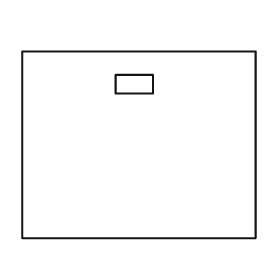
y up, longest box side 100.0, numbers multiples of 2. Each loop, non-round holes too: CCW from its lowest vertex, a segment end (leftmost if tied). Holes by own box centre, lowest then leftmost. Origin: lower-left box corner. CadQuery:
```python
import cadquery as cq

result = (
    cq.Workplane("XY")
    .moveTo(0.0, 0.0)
    .lineTo(100.0, 0.0)
    .lineTo(100.0, 80.0)
    .lineTo(0.0, 80.0)
    .close()
    .moveTo(40.0, 62.0)
    .lineTo(56.0, 62.0)
    .lineTo(56.0, 70.0)
    .lineTo(40.0, 70.0)
    .close()
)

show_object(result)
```